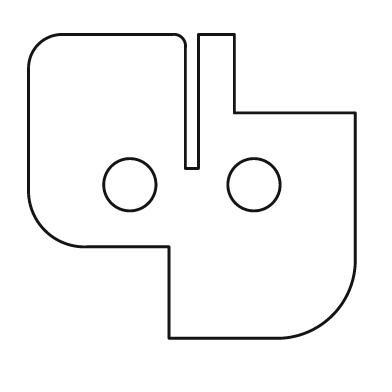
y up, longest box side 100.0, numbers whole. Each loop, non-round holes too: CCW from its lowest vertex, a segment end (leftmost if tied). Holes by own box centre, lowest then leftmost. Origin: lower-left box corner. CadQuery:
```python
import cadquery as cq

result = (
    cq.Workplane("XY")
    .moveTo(43.0, 0.0)
    .lineTo(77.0, 0.0)
    .threePointArc((93.0, 7.0), (100.0, 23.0))
    .lineTo(100.0, 69.0)
    .lineTo(63.0, 69.0)
    .lineTo(63.0, 93.0)
    .lineTo(52.0, 93.0)
    .lineTo(52.0, 52.0)
    .lineTo(48.0, 52.0)
    .lineTo(48.0, 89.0)
    .threePointArc((47.0, 92.0), (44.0, 93.0))
    .lineTo(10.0, 93.0)
    .threePointArc((3.0, 90.0), (0.0, 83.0))
    .lineTo(0.0, 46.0)
    .threePointArc((5.0, 33.0), (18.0, 28.0))
    .lineTo(43.0, 28.0)
    .close()
    .moveTo(31.0, 47.0)
    .circle(8.0)
    .moveTo(69.0, 47.0)
    .circle(8.0)
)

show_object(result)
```